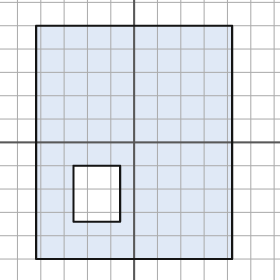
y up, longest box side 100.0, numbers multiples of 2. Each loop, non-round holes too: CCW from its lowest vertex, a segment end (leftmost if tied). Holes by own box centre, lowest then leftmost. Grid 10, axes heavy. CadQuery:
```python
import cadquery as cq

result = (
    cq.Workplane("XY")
    .moveTo(-42.0, -50.0)
    .lineTo(42.0, -50.0)
    .lineTo(42.0, 50.0)
    .lineTo(-42.0, 50.0)
    .close()
    .moveTo(-26.0, -34.0)
    .lineTo(-6.0, -34.0)
    .lineTo(-6.0, -10.0)
    .lineTo(-26.0, -10.0)
    .close()
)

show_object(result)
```